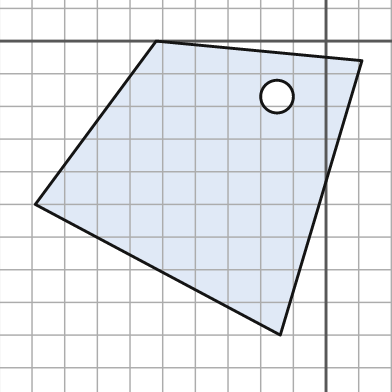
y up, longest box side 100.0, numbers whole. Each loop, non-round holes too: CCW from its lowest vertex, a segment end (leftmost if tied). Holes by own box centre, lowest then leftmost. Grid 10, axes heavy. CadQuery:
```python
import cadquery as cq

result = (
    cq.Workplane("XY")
    .moveTo(-14.0, -90.0)
    .lineTo(11.0, -6.0)
    .lineTo(-52.0, 0.0)
    .lineTo(-89.0, -50.0)
    .close()
    .moveTo(-15.0, -17.0)
    .circle(5.0)
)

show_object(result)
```